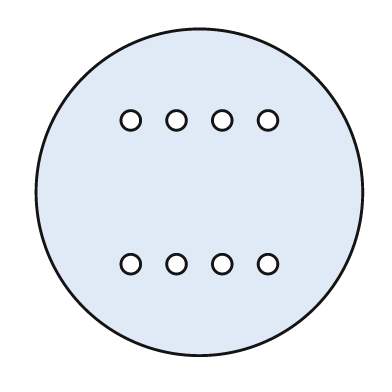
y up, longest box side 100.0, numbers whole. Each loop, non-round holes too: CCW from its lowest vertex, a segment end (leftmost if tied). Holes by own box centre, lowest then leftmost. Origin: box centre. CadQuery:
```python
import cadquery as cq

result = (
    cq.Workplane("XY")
    .moveTo(0.0, 0.0)
    .circle(50.0)
    .moveTo(-21.0, -22.0)
    .circle(3.0)
    .moveTo(-7.0, -22.0)
    .circle(3.0)
    .moveTo(7.0, -22.0)
    .circle(3.0)
    .moveTo(21.0, -22.0)
    .circle(3.0)
    .moveTo(-21.0, 22.0)
    .circle(3.0)
    .moveTo(-7.0, 22.0)
    .circle(3.0)
    .moveTo(7.0, 22.0)
    .circle(3.0)
    .moveTo(21.0, 22.0)
    .circle(3.0)
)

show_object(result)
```